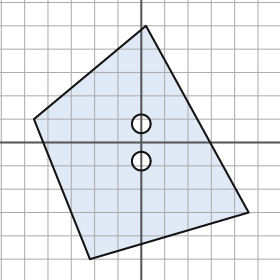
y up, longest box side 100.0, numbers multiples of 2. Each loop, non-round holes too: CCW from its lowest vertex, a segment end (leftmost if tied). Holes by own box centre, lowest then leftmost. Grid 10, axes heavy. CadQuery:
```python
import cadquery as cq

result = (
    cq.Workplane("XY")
    .moveTo(-22.0, -50.0)
    .lineTo(46.0, -30.0)
    .lineTo(2.0, 50.0)
    .lineTo(-46.0, 10.0)
    .close()
    .moveTo(0.0, -8.0)
    .circle(4.0)
    .moveTo(0.0, 8.0)
    .circle(4.0)
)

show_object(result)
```